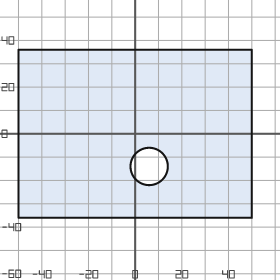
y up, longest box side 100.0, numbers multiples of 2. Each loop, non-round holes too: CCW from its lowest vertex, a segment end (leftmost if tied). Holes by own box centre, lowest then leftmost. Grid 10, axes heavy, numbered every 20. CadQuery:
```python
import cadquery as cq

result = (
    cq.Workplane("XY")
    .moveTo(-50.0, -36.0)
    .lineTo(50.0, -36.0)
    .lineTo(50.0, 36.0)
    .lineTo(-50.0, 36.0)
    .close()
    .moveTo(6.0, -14.0)
    .circle(8.0)
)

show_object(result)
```